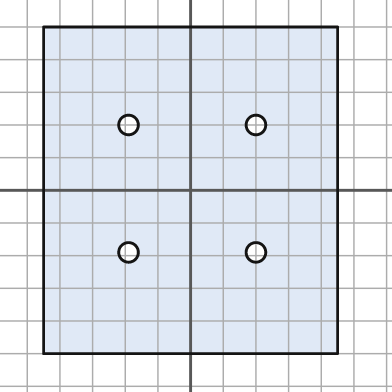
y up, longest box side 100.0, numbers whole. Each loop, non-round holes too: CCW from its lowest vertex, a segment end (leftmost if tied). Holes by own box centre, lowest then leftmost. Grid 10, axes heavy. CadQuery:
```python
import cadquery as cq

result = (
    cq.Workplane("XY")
    .moveTo(-45.0, -50.0)
    .lineTo(45.0, -50.0)
    .lineTo(45.0, 50.0)
    .lineTo(-45.0, 50.0)
    .close()
    .moveTo(-19.0, -19.0)
    .circle(3.0)
    .moveTo(20.0, -19.0)
    .circle(3.0)
    .moveTo(-19.0, 20.0)
    .circle(3.0)
    .moveTo(20.0, 20.0)
    .circle(3.0)
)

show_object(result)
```